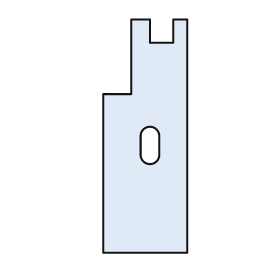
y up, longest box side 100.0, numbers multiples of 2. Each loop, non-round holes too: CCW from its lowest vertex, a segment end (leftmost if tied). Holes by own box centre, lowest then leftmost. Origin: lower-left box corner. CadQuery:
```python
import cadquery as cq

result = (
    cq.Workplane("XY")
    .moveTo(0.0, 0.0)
    .lineTo(36.0, 0.0)
    .lineTo(36.0, 100.0)
    .lineTo(30.0, 100.0)
    .lineTo(30.0, 90.0)
    .lineTo(20.0, 90.0)
    .lineTo(20.0, 100.0)
    .lineTo(12.0, 100.0)
    .lineTo(12.0, 68.0)
    .lineTo(0.0, 68.0)
    .close()
    .moveTo(16.0, 42.0)
    .threePointArc((20.0, 38.0), (24.0, 42.0))
    .lineTo(24.0, 50.0)
    .threePointArc((20.0, 54.0), (16.0, 50.0))
    .close()
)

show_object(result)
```